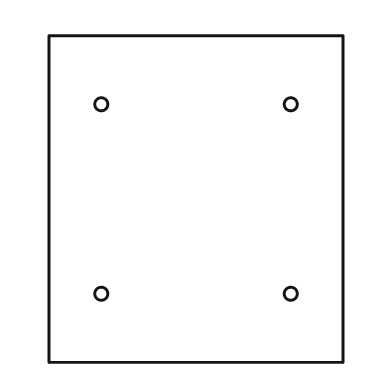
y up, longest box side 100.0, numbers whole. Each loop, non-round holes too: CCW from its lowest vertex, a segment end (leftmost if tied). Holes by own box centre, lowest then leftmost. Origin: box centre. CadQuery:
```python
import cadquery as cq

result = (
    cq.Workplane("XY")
    .moveTo(-45.0, -50.0)
    .lineTo(45.0, -50.0)
    .lineTo(45.0, 50.0)
    .lineTo(-45.0, 50.0)
    .close()
    .moveTo(-29.0, -29.0)
    .circle(2.0)
    .moveTo(29.0, -29.0)
    .circle(2.0)
    .moveTo(-29.0, 29.0)
    .circle(2.0)
    .moveTo(29.0, 29.0)
    .circle(2.0)
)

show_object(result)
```